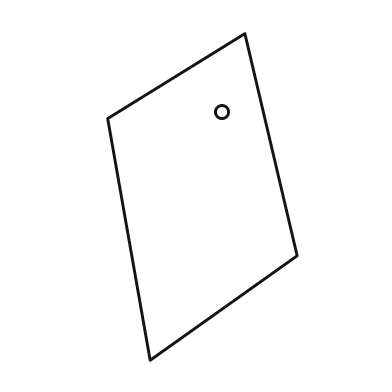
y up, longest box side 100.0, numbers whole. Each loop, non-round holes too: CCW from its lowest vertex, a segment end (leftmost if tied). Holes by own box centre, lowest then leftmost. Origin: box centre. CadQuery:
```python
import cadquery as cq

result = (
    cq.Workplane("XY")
    .moveTo(-16.0, -50.0)
    .lineTo(29.0, -18.0)
    .lineTo(13.0, 50.0)
    .lineTo(-29.0, 24.0)
    .close()
    .moveTo(6.0, 26.0)
    .circle(2.0)
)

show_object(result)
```